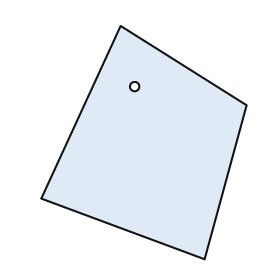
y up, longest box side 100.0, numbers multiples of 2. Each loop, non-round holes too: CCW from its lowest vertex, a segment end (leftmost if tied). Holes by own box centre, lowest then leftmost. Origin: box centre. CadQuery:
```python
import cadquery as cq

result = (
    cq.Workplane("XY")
    .moveTo(26.0, -50.0)
    .lineTo(44.0, 16.0)
    .lineTo(-10.0, 50.0)
    .lineTo(-44.0, -24.0)
    .close()
    .moveTo(-4.0, 24.0)
    .circle(2.0)
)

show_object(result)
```